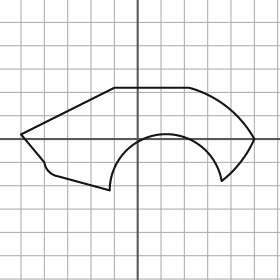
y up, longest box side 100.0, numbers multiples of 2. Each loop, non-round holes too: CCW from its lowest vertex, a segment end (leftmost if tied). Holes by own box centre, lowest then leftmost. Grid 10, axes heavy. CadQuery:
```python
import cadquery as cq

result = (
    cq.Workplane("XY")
    .moveTo(-12.0, -22.0)
    .threePointArc((10.0, 2.0), (36.0, -18.0))
    .threePointArc((44.0, -10.0), (50.0, 0.0))
    .threePointArc((38.0, 14.0), (22.0, 22.0))
    .lineTo(-10.0, 22.0)
    .lineTo(-50.0, 2.0)
    .lineTo(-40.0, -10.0)
    .threePointArc((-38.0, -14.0), (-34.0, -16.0))
    .close()
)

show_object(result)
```